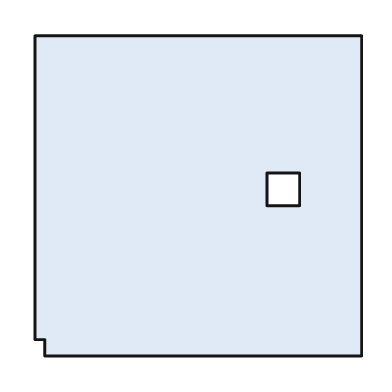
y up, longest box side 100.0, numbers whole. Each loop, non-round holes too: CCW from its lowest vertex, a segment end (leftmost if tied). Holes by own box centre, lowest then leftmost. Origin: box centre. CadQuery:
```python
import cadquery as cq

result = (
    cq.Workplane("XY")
    .moveTo(-47.0, -49.0)
    .lineTo(50.0, -49.0)
    .lineTo(50.0, 49.0)
    .lineTo(-50.0, 49.0)
    .lineTo(-50.0, -44.0)
    .lineTo(-47.0, -44.0)
    .close()
    .moveTo(21.0, -3.0)
    .lineTo(31.0, -3.0)
    .lineTo(31.0, 7.0)
    .lineTo(21.0, 7.0)
    .close()
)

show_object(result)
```